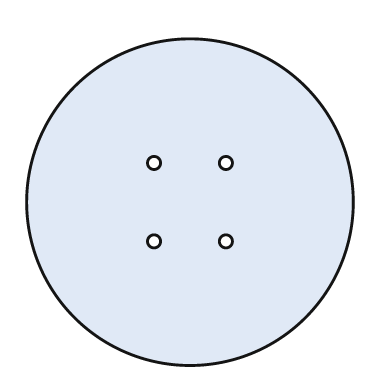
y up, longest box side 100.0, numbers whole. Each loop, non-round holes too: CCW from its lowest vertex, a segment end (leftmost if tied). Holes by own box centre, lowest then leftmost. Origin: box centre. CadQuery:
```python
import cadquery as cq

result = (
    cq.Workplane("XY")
    .moveTo(0.0, 0.0)
    .circle(50.0)
    .moveTo(-11.0, -12.0)
    .circle(2.0)
    .moveTo(11.0, -12.0)
    .circle(2.0)
    .moveTo(-11.0, 12.0)
    .circle(2.0)
    .moveTo(11.0, 12.0)
    .circle(2.0)
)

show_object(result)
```